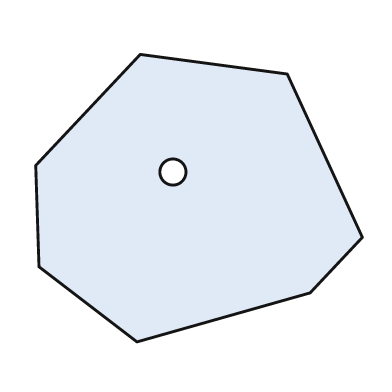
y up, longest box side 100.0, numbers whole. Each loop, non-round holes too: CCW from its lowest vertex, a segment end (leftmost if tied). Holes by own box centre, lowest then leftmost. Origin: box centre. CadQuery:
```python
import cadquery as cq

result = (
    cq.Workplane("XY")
    .moveTo(-19.0, -44.0)
    .lineTo(34.0, -29.0)
    .lineTo(50.0, -12.0)
    .lineTo(27.0, 38.0)
    .lineTo(-18.0, 44.0)
    .lineTo(-50.0, 10.0)
    .lineTo(-49.0, -21.0)
    .close()
    .moveTo(-8.0, 8.0)
    .circle(4.0)
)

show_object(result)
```